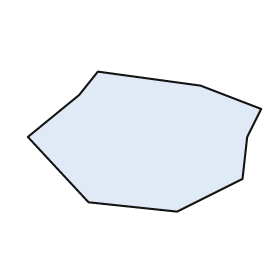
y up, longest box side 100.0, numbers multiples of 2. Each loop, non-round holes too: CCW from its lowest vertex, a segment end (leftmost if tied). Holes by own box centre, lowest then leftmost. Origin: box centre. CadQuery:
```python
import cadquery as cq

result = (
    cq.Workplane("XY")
    .moveTo(14.0, -30.0)
    .lineTo(42.0, -16.0)
    .lineTo(44.0, 2.0)
    .lineTo(50.0, 14.0)
    .lineTo(24.0, 24.0)
    .lineTo(-20.0, 30.0)
    .lineTo(-28.0, 20.0)
    .lineTo(-50.0, 2.0)
    .lineTo(-24.0, -26.0)
    .close()
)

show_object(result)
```